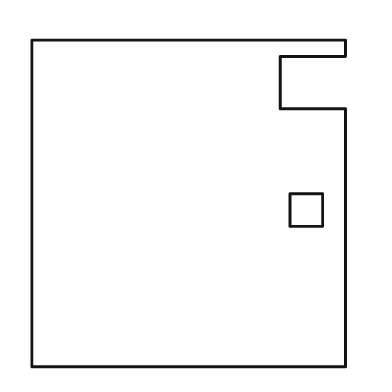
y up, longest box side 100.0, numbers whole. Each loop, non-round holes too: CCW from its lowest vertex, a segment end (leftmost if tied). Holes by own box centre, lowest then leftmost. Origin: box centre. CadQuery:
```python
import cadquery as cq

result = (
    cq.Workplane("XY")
    .moveTo(-48.0, -50.0)
    .lineTo(48.0, -50.0)
    .lineTo(48.0, 29.0)
    .lineTo(28.0, 29.0)
    .lineTo(28.0, 45.0)
    .lineTo(48.0, 45.0)
    .lineTo(48.0, 50.0)
    .lineTo(-48.0, 50.0)
    .close()
    .moveTo(31.0, -7.0)
    .lineTo(41.0, -7.0)
    .lineTo(41.0, 3.0)
    .lineTo(31.0, 3.0)
    .close()
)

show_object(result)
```